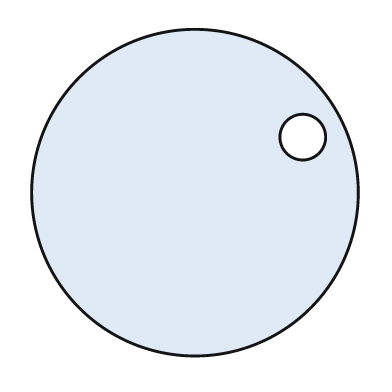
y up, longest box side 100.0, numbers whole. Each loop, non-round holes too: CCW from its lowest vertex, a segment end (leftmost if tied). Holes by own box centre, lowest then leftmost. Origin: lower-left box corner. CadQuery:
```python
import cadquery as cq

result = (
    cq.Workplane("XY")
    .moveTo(50.0, 50.0)
    .circle(50.0)
    .moveTo(83.0, 67.0)
    .circle(7.0)
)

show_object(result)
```